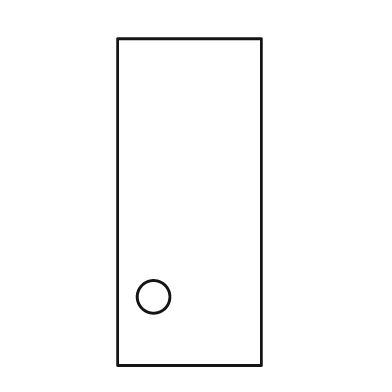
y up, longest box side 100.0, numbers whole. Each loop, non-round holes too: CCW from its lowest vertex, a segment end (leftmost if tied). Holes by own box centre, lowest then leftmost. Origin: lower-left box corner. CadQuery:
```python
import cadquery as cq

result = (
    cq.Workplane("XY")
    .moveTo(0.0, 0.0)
    .lineTo(44.0, 0.0)
    .lineTo(44.0, 100.0)
    .lineTo(0.0, 100.0)
    .close()
    .moveTo(11.0, 21.0)
    .circle(5.0)
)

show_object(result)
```